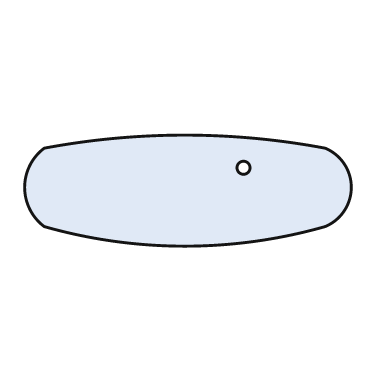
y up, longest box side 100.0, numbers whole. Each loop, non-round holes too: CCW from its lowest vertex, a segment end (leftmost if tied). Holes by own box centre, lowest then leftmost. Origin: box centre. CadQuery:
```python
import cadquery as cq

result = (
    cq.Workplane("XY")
    .moveTo(-44.0, -11.0)
    .threePointArc((-1.0, -17.0), (42.0, -11.0))
    .threePointArc((50.0, 1.0), (42.0, 13.0))
    .threePointArc((-1.0, 17.0), (-44.0, 13.0))
    .threePointArc((-50.0, 1.0), (-44.0, -11.0))
    .close()
    .moveTo(17.0, 7.0)
    .circle(2.0)
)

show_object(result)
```